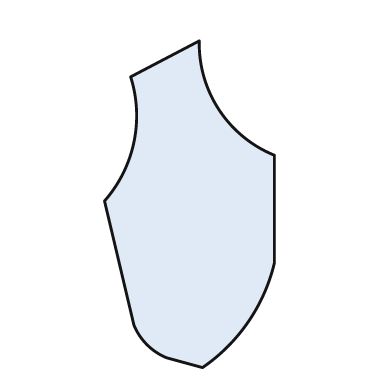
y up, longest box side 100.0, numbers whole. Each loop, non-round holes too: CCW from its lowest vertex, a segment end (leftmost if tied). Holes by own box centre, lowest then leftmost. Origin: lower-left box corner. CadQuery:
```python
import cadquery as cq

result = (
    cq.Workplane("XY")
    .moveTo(30.0, 0.0)
    .threePointArc((44.0, 14.0), (52.0, 32.0))
    .lineTo(52.0, 65.0)
    .threePointArc((35.0, 79.0), (29.0, 100.0))
    .lineTo(8.0, 89.0)
    .threePointArc((9.0, 69.0), (0.0, 51.0))
    .lineTo(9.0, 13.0)
    .threePointArc((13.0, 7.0), (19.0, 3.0))
    .close()
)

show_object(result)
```